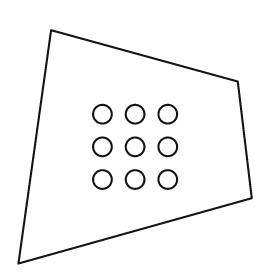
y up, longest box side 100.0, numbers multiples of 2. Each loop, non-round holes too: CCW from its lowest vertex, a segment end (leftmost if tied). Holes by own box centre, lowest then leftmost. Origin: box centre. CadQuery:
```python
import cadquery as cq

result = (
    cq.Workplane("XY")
    .moveTo(-50.0, -50.0)
    .lineTo(50.0, -22.0)
    .lineTo(44.0, 28.0)
    .lineTo(-36.0, 50.0)
    .close()
    .moveTo(-14.0, -14.0)
    .circle(4.0)
    .moveTo(0.0, -14.0)
    .circle(4.0)
    .moveTo(14.0, -14.0)
    .circle(4.0)
    .moveTo(-14.0, 0.0)
    .circle(4.0)
    .moveTo(0.0, 0.0)
    .circle(4.0)
    .moveTo(14.0, 0.0)
    .circle(4.0)
    .moveTo(-14.0, 14.0)
    .circle(4.0)
    .moveTo(0.0, 14.0)
    .circle(4.0)
    .moveTo(14.0, 14.0)
    .circle(4.0)
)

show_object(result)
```